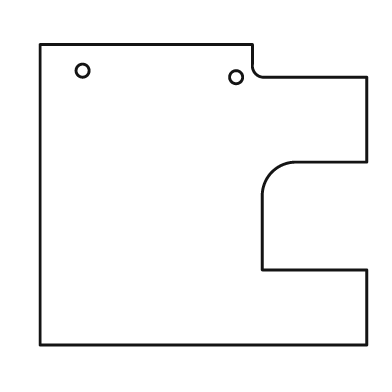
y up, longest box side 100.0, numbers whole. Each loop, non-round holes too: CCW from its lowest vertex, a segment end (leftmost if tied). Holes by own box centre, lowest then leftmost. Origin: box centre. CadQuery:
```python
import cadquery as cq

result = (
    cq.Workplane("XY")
    .moveTo(-50.0, -46.0)
    .lineTo(50.0, -46.0)
    .lineTo(50.0, -23.0)
    .lineTo(18.0, -23.0)
    .lineTo(18.0, 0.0)
    .threePointArc((21.0, 7.0), (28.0, 10.0))
    .lineTo(50.0, 10.0)
    .lineTo(50.0, 36.0)
    .lineTo(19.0, 36.0)
    .threePointArc((16.0, 37.0), (15.0, 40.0))
    .lineTo(15.0, 46.0)
    .lineTo(-50.0, 46.0)
    .close()
    .moveTo(10.0, 36.0)
    .circle(2.0)
    .moveTo(-37.0, 38.0)
    .circle(2.0)
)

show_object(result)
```